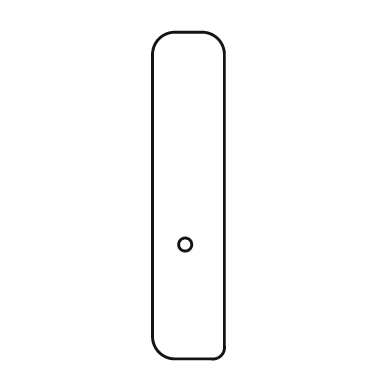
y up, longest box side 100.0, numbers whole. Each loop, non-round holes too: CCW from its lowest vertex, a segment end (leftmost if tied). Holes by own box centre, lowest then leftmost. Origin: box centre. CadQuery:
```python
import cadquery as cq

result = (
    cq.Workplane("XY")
    .moveTo(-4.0, -50.0)
    .lineTo(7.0, -50.0)
    .threePointArc((10.0, -49.0), (11.0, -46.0))
    .lineTo(11.0, 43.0)
    .threePointArc((9.0, 48.0), (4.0, 50.0))
    .lineTo(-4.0, 50.0)
    .threePointArc((-9.0, 48.0), (-11.0, 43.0))
    .lineTo(-11.0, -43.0)
    .threePointArc((-9.0, -48.0), (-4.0, -50.0))
    .close()
    .moveTo(-1.0, -15.0)
    .circle(2.0)
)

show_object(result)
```